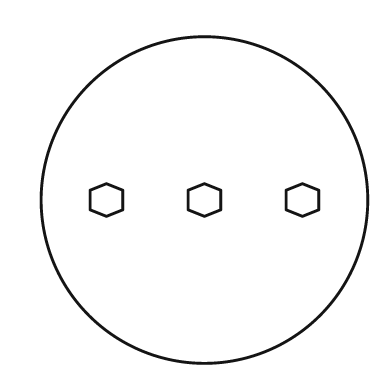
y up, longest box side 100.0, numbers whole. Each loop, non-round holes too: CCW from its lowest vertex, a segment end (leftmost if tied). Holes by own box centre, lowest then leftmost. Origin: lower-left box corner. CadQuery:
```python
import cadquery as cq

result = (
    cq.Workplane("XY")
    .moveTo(50.0, 50.0)
    .circle(50.0)
    .moveTo(20.0, 45.0)
    .lineTo(25.0, 47.0)
    .lineTo(25.0, 53.0)
    .lineTo(20.0, 55.0)
    .lineTo(15.0, 53.0)
    .lineTo(15.0, 47.0)
    .close()
    .moveTo(50.0, 45.0)
    .lineTo(55.0, 47.0)
    .lineTo(55.0, 53.0)
    .lineTo(50.0, 55.0)
    .lineTo(45.0, 53.0)
    .lineTo(45.0, 47.0)
    .close()
    .moveTo(80.0, 45.0)
    .lineTo(85.0, 47.0)
    .lineTo(85.0, 53.0)
    .lineTo(80.0, 55.0)
    .lineTo(75.0, 53.0)
    .lineTo(75.0, 47.0)
    .close()
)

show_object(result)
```